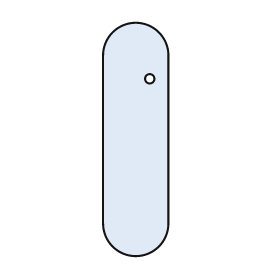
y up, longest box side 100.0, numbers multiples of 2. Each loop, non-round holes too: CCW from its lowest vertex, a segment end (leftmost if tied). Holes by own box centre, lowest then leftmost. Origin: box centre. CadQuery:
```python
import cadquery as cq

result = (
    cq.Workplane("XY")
    .moveTo(-14.0, -36.0)
    .threePointArc((0.0, -50.0), (14.0, -36.0))
    .lineTo(14.0, 36.0)
    .threePointArc((0.0, 50.0), (-14.0, 36.0))
    .close()
    .moveTo(6.0, 26.0)
    .circle(2.0)
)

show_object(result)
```